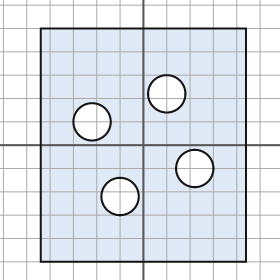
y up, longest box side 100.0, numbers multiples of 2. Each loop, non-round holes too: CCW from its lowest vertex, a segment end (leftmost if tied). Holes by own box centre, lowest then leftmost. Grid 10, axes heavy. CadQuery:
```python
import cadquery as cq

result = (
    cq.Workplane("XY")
    .moveTo(-44.0, -50.0)
    .lineTo(44.0, -50.0)
    .lineTo(44.0, 50.0)
    .lineTo(-44.0, 50.0)
    .close()
    .moveTo(-10.0, -22.0)
    .circle(8.0)
    .moveTo(22.0, -10.0)
    .circle(8.0)
    .moveTo(-22.0, 10.0)
    .circle(8.0)
    .moveTo(10.0, 22.0)
    .circle(8.0)
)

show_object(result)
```